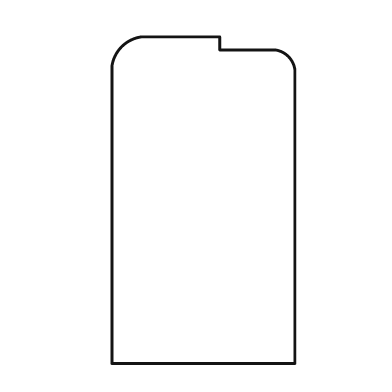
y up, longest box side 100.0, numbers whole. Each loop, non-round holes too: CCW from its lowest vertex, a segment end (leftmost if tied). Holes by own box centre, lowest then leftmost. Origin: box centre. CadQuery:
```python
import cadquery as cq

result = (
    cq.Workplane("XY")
    .moveTo(-28.0, -50.0)
    .lineTo(28.0, -50.0)
    .lineTo(28.0, 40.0)
    .threePointArc((26.0, 44.0), (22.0, 46.0))
    .lineTo(5.0, 46.0)
    .lineTo(5.0, 50.0)
    .lineTo(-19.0, 50.0)
    .threePointArc((-25.0, 47.0), (-28.0, 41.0))
    .close()
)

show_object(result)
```